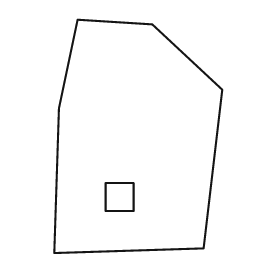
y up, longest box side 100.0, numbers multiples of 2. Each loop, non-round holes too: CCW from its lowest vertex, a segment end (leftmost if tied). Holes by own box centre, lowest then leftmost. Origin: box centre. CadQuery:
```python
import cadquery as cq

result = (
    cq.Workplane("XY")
    .moveTo(-36.0, -50.0)
    .lineTo(28.0, -48.0)
    .lineTo(36.0, 20.0)
    .lineTo(6.0, 48.0)
    .lineTo(-26.0, 50.0)
    .lineTo(-34.0, 12.0)
    .close()
    .moveTo(-14.0, -32.0)
    .lineTo(-2.0, -32.0)
    .lineTo(-2.0, -20.0)
    .lineTo(-14.0, -20.0)
    .close()
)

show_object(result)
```